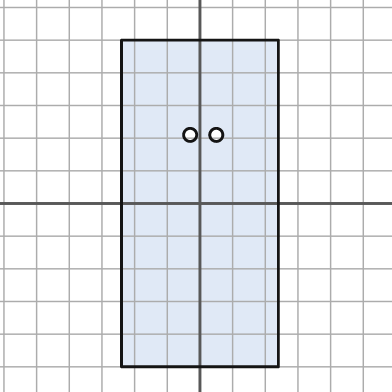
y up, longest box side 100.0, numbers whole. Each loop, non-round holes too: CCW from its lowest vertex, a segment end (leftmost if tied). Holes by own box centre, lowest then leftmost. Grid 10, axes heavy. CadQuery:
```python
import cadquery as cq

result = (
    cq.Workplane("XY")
    .moveTo(-24.0, -50.0)
    .lineTo(24.0, -50.0)
    .lineTo(24.0, 50.0)
    .lineTo(-24.0, 50.0)
    .close()
    .moveTo(-3.0, 21.0)
    .circle(2.0)
    .moveTo(5.0, 21.0)
    .circle(2.0)
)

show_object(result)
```